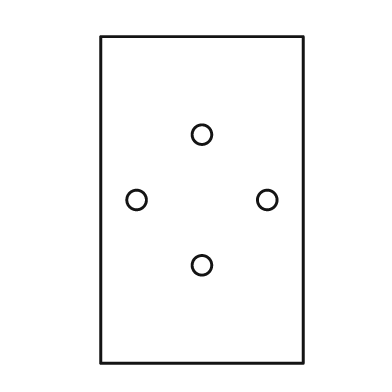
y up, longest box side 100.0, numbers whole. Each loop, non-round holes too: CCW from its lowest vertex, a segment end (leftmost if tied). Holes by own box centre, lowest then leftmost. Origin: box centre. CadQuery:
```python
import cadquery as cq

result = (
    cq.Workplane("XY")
    .moveTo(-31.0, -50.0)
    .lineTo(31.0, -50.0)
    .lineTo(31.0, 50.0)
    .lineTo(-31.0, 50.0)
    .close()
    .moveTo(0.0, -20.0)
    .circle(3.0)
    .moveTo(-20.0, 0.0)
    .circle(3.0)
    .moveTo(20.0, 0.0)
    .circle(3.0)
    .moveTo(0.0, 20.0)
    .circle(3.0)
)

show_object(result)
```